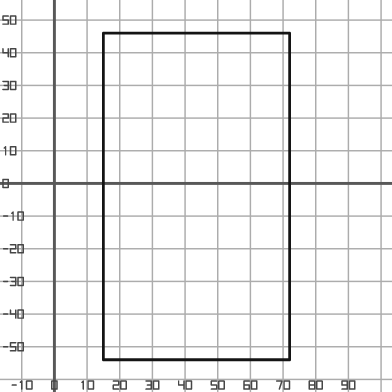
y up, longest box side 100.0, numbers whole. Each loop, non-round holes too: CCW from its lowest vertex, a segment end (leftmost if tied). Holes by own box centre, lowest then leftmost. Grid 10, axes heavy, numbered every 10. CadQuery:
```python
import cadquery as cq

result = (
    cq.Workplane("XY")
    .moveTo(15.0, -54.0)
    .lineTo(72.0, -54.0)
    .lineTo(72.0, 46.0)
    .lineTo(15.0, 46.0)
    .close()
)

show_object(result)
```